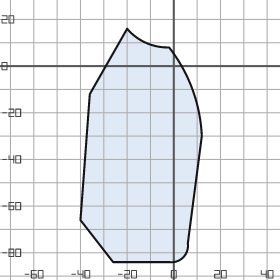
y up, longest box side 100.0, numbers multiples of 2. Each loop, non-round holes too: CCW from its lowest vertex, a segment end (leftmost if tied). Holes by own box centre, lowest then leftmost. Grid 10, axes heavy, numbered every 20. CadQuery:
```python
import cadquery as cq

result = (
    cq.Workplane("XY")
    .moveTo(-26.0, -84.0)
    .lineTo(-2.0, -84.0)
    .threePointArc((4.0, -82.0), (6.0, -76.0))
    .lineTo(12.0, -30.0)
    .threePointArc((8.0, -10.0), (-2.0, 8.0))
    .threePointArc((-12.0, 10.0), (-20.0, 16.0))
    .lineTo(-36.0, -12.0)
    .lineTo(-40.0, -66.0)
    .close()
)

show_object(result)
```